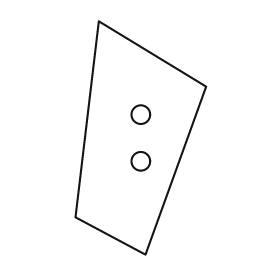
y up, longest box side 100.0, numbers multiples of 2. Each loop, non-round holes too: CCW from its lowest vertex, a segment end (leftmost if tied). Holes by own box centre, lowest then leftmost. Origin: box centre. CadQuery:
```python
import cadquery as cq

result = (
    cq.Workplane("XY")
    .moveTo(2.0, -50.0)
    .lineTo(28.0, 22.0)
    .lineTo(-18.0, 50.0)
    .lineTo(-28.0, -34.0)
    .close()
    .moveTo(0.0, -10.0)
    .circle(4.0)
    .moveTo(0.0, 10.0)
    .circle(4.0)
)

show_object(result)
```